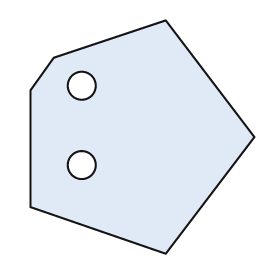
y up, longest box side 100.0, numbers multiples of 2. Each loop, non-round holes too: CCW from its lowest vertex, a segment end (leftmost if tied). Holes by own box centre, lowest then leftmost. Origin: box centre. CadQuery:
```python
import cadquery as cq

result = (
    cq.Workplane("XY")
    .moveTo(10.0, -50.0)
    .lineTo(48.0, 0.0)
    .lineTo(10.0, 50.0)
    .lineTo(-38.0, 34.0)
    .lineTo(-48.0, 20.0)
    .lineTo(-48.0, -30.0)
    .close()
    .moveTo(-26.0, -12.0)
    .circle(6.0)
    .moveTo(-26.0, 22.0)
    .circle(6.0)
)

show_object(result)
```